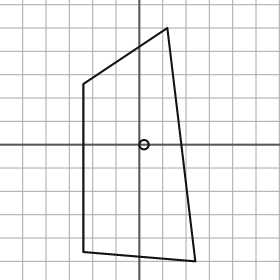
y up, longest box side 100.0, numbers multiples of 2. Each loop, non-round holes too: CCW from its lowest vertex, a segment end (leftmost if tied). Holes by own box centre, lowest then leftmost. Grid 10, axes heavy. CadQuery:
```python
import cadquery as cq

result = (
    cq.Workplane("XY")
    .moveTo(24.0, -50.0)
    .lineTo(12.0, 50.0)
    .lineTo(-24.0, 26.0)
    .lineTo(-24.0, -46.0)
    .close()
    .moveTo(2.0, 0.0)
    .circle(2.0)
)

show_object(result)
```